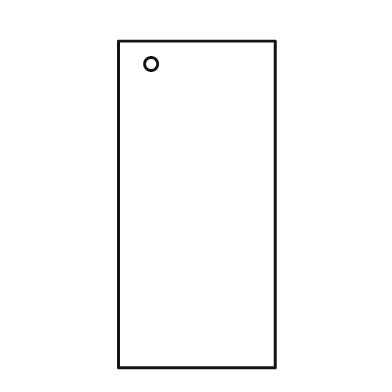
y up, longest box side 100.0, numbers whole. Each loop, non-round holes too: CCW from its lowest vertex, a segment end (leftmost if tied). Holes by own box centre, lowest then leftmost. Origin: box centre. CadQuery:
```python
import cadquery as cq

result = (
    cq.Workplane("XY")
    .moveTo(-24.0, -50.0)
    .lineTo(24.0, -50.0)
    .lineTo(24.0, 50.0)
    .lineTo(-24.0, 50.0)
    .close()
    .moveTo(-14.0, 43.0)
    .circle(2.0)
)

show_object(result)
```